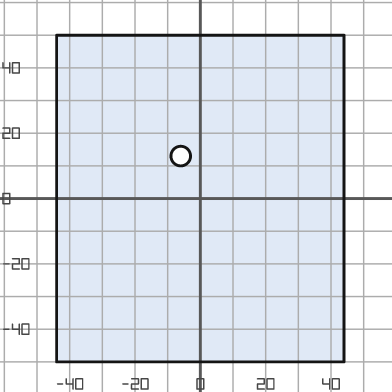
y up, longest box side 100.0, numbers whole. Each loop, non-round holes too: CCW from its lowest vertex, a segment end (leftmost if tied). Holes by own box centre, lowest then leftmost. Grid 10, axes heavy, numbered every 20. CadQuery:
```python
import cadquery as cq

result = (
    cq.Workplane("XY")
    .moveTo(-44.0, -50.0)
    .lineTo(44.0, -50.0)
    .lineTo(44.0, 50.0)
    .lineTo(-44.0, 50.0)
    .close()
    .moveTo(-6.0, 13.0)
    .circle(3.0)
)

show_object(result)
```